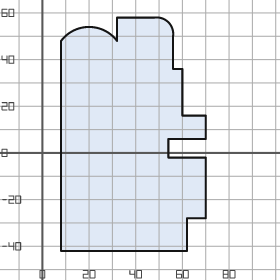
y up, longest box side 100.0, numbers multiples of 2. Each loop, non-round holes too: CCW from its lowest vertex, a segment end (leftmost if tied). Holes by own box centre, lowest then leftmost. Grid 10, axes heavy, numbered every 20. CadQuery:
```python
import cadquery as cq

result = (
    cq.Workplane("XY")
    .moveTo(8.0, -42.0)
    .lineTo(62.0, -42.0)
    .lineTo(62.0, -28.0)
    .lineTo(70.0, -28.0)
    .lineTo(70.0, -2.0)
    .lineTo(54.0, -2.0)
    .lineTo(54.0, 6.0)
    .lineTo(70.0, 6.0)
    .lineTo(70.0, 16.0)
    .lineTo(60.0, 16.0)
    .lineTo(60.0, 36.0)
    .lineTo(56.0, 36.0)
    .lineTo(56.0, 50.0)
    .threePointArc((54.0, 56.0), (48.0, 58.0))
    .lineTo(32.0, 58.0)
    .lineTo(32.0, 48.0)
    .threePointArc((20.0, 54.0), (8.0, 48.0))
    .close()
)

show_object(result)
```